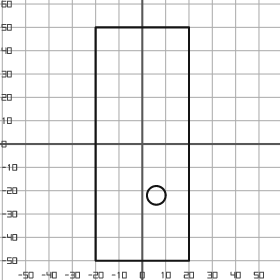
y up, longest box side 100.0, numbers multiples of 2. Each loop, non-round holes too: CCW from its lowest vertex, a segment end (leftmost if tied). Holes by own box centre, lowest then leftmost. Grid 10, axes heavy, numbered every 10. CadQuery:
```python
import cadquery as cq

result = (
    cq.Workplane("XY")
    .moveTo(-20.0, -50.0)
    .lineTo(20.0, -50.0)
    .lineTo(20.0, 50.0)
    .lineTo(-20.0, 50.0)
    .close()
    .moveTo(6.0, -22.0)
    .circle(4.0)
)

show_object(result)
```